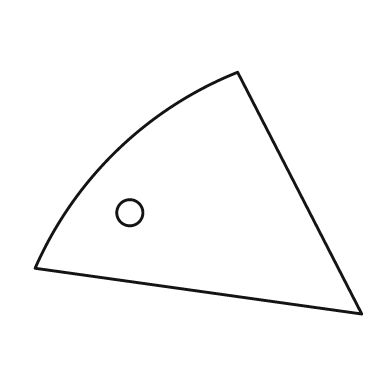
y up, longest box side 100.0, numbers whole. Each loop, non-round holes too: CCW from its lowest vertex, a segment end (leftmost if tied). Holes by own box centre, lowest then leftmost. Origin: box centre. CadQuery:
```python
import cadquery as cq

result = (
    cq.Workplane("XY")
    .moveTo(50.0, -37.0)
    .lineTo(12.0, 37.0)
    .threePointArc((-25.0, 13.0), (-50.0, -23.0))
    .close()
    .moveTo(-21.0, -6.0)
    .circle(4.0)
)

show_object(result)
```